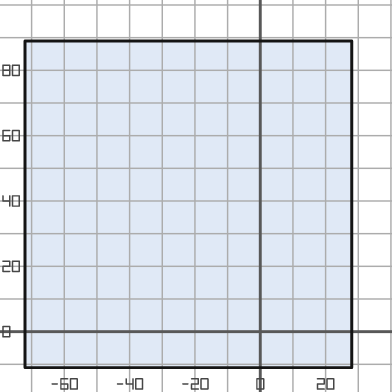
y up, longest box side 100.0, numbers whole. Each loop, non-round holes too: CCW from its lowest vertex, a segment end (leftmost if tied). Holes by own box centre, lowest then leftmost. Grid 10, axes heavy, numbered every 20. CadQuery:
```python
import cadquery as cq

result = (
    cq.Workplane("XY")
    .moveTo(-72.0, -11.0)
    .lineTo(28.0, -11.0)
    .lineTo(28.0, 89.0)
    .lineTo(-72.0, 89.0)
    .close()
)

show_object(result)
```